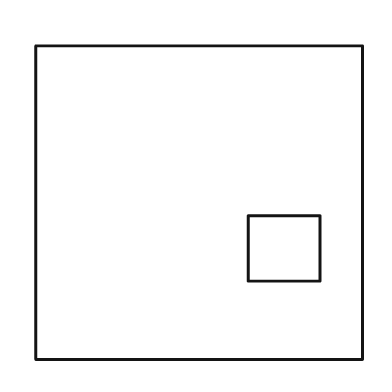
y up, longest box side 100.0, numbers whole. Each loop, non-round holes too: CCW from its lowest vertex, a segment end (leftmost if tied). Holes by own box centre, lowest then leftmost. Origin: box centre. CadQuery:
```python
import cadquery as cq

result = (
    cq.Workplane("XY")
    .moveTo(-50.0, -48.0)
    .lineTo(50.0, -48.0)
    .lineTo(50.0, 48.0)
    .lineTo(-50.0, 48.0)
    .close()
    .moveTo(15.0, -24.0)
    .lineTo(37.0, -24.0)
    .lineTo(37.0, -4.0)
    .lineTo(15.0, -4.0)
    .close()
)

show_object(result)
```